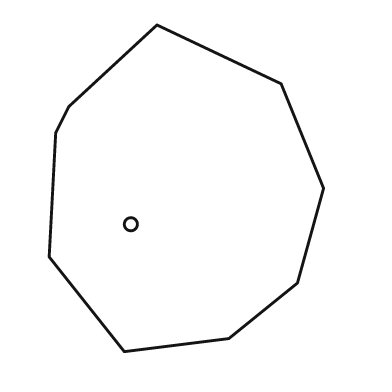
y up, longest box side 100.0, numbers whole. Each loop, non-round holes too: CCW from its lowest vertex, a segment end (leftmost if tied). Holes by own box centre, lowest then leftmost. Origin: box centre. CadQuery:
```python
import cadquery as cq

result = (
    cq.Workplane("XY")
    .moveTo(-19.0, -50.0)
    .lineTo(13.0, -46.0)
    .lineTo(34.0, -29.0)
    .lineTo(42.0, 0.0)
    .lineTo(29.0, 32.0)
    .lineTo(-9.0, 50.0)
    .lineTo(-36.0, 25.0)
    .lineTo(-40.0, 17.0)
    .lineTo(-42.0, -21.0)
    .close()
    .moveTo(-17.0, -11.0)
    .circle(2.0)
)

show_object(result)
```